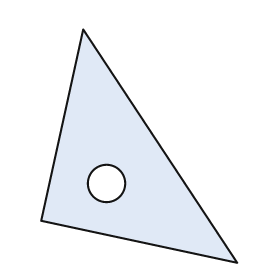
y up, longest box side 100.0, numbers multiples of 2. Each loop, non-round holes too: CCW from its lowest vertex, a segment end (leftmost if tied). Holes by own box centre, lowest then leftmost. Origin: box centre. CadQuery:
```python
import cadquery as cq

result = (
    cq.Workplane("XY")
    .moveTo(42.0, -50.0)
    .lineTo(-24.0, 50.0)
    .lineTo(-42.0, -32.0)
    .close()
    .moveTo(-14.0, -16.0)
    .circle(8.0)
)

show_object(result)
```